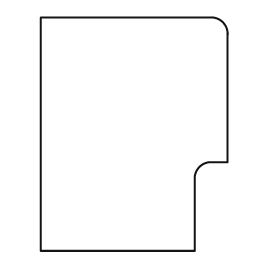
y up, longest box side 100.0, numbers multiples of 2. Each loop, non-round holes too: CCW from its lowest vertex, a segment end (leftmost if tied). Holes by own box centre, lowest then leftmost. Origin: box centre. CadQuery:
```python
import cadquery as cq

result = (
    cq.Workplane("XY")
    .moveTo(-40.0, -50.0)
    .lineTo(26.0, -50.0)
    .lineTo(26.0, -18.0)
    .threePointArc((28.0, -14.0), (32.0, -12.0))
    .lineTo(40.0, -12.0)
    .lineTo(40.0, 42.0)
    .threePointArc((38.0, 48.0), (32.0, 50.0))
    .lineTo(-40.0, 50.0)
    .close()
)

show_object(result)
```